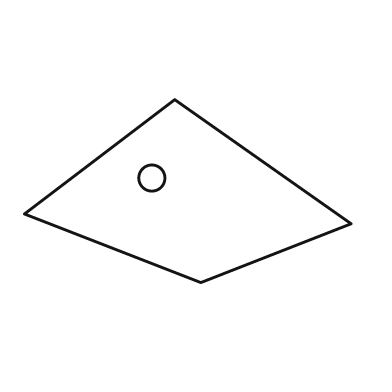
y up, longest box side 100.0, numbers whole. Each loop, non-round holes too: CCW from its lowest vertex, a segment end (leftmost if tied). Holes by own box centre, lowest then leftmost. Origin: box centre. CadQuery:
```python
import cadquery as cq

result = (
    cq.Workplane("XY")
    .moveTo(4.0, -28.0)
    .lineTo(50.0, -10.0)
    .lineTo(-4.0, 28.0)
    .lineTo(-50.0, -7.0)
    .close()
    .moveTo(-11.0, 4.0)
    .circle(4.0)
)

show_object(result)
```